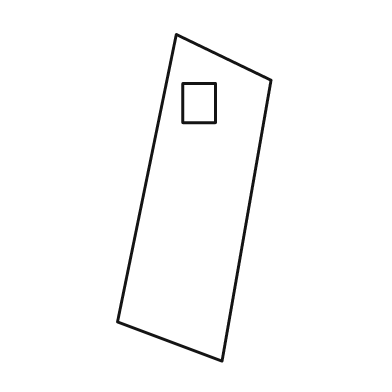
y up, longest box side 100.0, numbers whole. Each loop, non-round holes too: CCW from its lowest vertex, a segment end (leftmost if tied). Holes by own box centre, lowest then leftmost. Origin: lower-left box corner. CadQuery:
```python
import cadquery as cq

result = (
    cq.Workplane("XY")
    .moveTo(32.0, 0.0)
    .lineTo(47.0, 86.0)
    .lineTo(18.0, 100.0)
    .lineTo(0.0, 12.0)
    .close()
    .moveTo(20.0, 73.0)
    .lineTo(30.0, 73.0)
    .lineTo(30.0, 85.0)
    .lineTo(20.0, 85.0)
    .close()
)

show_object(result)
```